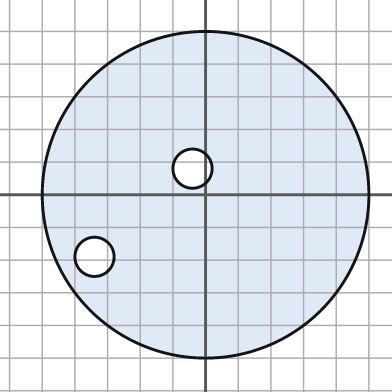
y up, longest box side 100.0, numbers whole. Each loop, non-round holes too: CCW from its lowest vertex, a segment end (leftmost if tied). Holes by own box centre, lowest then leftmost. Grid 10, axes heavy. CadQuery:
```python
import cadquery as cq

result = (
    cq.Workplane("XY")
    .moveTo(0.0, 0.0)
    .circle(50.0)
    .moveTo(-34.0, -19.0)
    .circle(6.0)
    .moveTo(-4.0, 8.0)
    .circle(6.0)
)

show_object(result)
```